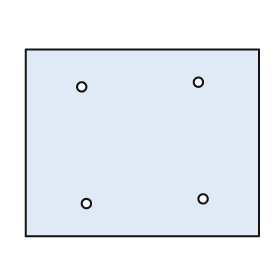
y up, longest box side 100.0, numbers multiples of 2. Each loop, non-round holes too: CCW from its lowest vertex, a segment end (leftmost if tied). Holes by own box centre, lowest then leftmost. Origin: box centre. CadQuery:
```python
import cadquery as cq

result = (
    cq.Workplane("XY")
    .moveTo(-50.0, -40.0)
    .lineTo(50.0, -40.0)
    .lineTo(50.0, 40.0)
    .lineTo(-50.0, 40.0)
    .close()
    .moveTo(-24.0, -26.0)
    .circle(2.0)
    .moveTo(26.0, -24.0)
    .circle(2.0)
    .moveTo(-26.0, 24.0)
    .circle(2.0)
    .moveTo(24.0, 26.0)
    .circle(2.0)
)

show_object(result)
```